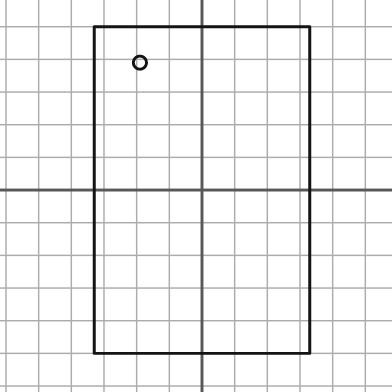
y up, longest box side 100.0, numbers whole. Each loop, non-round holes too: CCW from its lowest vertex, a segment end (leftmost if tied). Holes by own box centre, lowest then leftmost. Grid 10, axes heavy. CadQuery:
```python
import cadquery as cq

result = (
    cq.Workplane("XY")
    .moveTo(-33.0, -50.0)
    .lineTo(33.0, -50.0)
    .lineTo(33.0, 50.0)
    .lineTo(-33.0, 50.0)
    .close()
    .moveTo(-19.0, 39.0)
    .circle(2.0)
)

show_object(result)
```